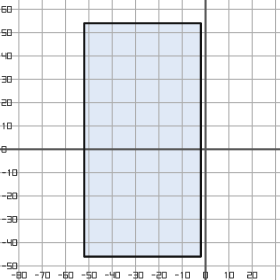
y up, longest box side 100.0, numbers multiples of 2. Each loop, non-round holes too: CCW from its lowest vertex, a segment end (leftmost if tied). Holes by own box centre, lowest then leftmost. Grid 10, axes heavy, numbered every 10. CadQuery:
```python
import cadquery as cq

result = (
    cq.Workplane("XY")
    .moveTo(-52.0, -46.0)
    .lineTo(-2.0, -46.0)
    .lineTo(-2.0, 54.0)
    .lineTo(-52.0, 54.0)
    .close()
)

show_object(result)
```